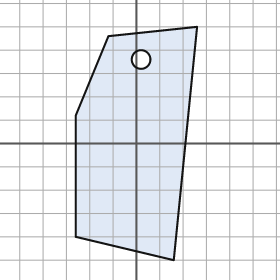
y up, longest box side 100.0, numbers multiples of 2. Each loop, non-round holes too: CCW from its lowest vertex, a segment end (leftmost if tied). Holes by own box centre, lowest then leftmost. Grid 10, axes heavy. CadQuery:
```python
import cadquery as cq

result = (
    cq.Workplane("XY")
    .moveTo(16.0, -50.0)
    .lineTo(26.0, 50.0)
    .lineTo(-12.0, 46.0)
    .lineTo(-26.0, 12.0)
    .lineTo(-26.0, -40.0)
    .close()
    .moveTo(2.0, 36.0)
    .circle(4.0)
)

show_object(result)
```